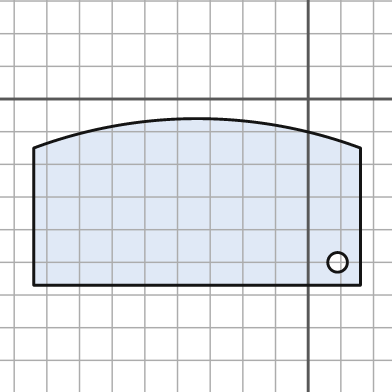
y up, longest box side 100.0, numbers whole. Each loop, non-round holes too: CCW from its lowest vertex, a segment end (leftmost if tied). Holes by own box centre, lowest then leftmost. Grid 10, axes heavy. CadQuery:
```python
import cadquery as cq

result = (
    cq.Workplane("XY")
    .moveTo(-84.0, -57.0)
    .lineTo(16.0, -57.0)
    .lineTo(16.0, -15.0)
    .threePointArc((-34.0, -6.0), (-84.0, -15.0))
    .close()
    .moveTo(9.0, -50.0)
    .circle(3.0)
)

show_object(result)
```